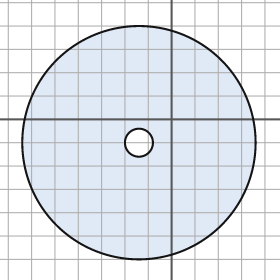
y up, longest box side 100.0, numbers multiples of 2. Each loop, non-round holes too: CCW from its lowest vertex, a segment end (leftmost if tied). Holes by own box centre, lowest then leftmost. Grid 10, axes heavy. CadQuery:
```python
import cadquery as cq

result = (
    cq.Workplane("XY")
    .moveTo(-14.0, -10.0)
    .circle(50.0)
    .moveTo(-14.0, -10.0)
    .circle(6.0)
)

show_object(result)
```